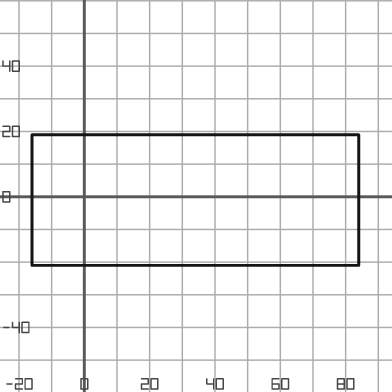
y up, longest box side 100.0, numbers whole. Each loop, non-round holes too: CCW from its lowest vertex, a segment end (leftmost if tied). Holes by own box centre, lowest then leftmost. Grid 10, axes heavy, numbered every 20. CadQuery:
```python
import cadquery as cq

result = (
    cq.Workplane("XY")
    .moveTo(-16.0, -21.0)
    .lineTo(84.0, -21.0)
    .lineTo(84.0, 19.0)
    .lineTo(-16.0, 19.0)
    .close()
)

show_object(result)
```